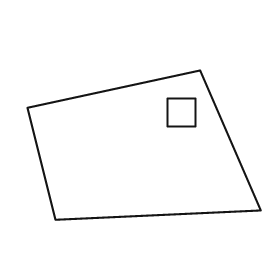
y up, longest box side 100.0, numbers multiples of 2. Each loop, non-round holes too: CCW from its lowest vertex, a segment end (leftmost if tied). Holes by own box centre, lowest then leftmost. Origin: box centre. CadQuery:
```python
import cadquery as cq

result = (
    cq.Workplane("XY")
    .moveTo(-38.0, -32.0)
    .lineTo(50.0, -28.0)
    .lineTo(24.0, 32.0)
    .lineTo(-50.0, 16.0)
    .close()
    .moveTo(10.0, 8.0)
    .lineTo(22.0, 8.0)
    .lineTo(22.0, 20.0)
    .lineTo(10.0, 20.0)
    .close()
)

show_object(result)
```